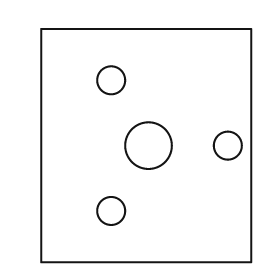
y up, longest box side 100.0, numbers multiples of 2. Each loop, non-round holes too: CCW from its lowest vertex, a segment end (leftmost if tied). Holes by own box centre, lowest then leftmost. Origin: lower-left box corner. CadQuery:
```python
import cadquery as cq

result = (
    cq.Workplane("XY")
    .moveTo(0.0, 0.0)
    .lineTo(90.0, 0.0)
    .lineTo(90.0, 100.0)
    .lineTo(0.0, 100.0)
    .close()
    .moveTo(30.0, 22.0)
    .circle(6.0)
    .moveTo(46.0, 50.0)
    .circle(10.0)
    .moveTo(80.0, 50.0)
    .circle(6.0)
    .moveTo(30.0, 78.0)
    .circle(6.0)
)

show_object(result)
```